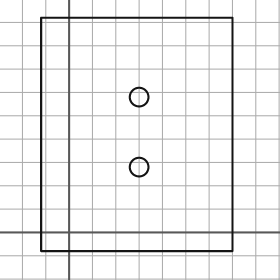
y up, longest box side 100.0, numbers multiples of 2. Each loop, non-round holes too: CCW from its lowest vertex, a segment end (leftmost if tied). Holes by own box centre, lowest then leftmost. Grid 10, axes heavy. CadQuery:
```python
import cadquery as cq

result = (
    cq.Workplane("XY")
    .moveTo(-12.0, -8.0)
    .lineTo(70.0, -8.0)
    .lineTo(70.0, 92.0)
    .lineTo(-12.0, 92.0)
    .close()
    .moveTo(30.0, 28.0)
    .circle(4.0)
    .moveTo(30.0, 58.0)
    .circle(4.0)
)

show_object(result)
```